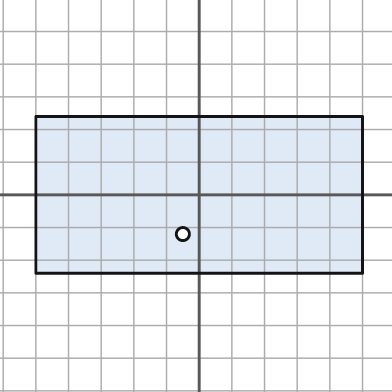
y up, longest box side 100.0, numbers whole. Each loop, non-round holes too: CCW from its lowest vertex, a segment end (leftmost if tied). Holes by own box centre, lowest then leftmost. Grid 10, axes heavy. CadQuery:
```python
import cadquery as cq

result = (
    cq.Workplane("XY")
    .moveTo(-50.0, -24.0)
    .lineTo(50.0, -24.0)
    .lineTo(50.0, 24.0)
    .lineTo(-50.0, 24.0)
    .close()
    .moveTo(-5.0, -12.0)
    .circle(2.0)
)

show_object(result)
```